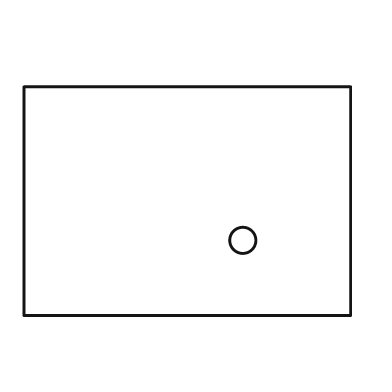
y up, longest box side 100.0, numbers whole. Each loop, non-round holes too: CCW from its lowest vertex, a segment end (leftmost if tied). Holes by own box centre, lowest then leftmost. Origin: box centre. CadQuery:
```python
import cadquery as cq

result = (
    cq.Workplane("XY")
    .moveTo(-50.0, -35.0)
    .lineTo(50.0, -35.0)
    .lineTo(50.0, 35.0)
    .lineTo(-50.0, 35.0)
    .close()
    .moveTo(17.0, -12.0)
    .circle(4.0)
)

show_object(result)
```